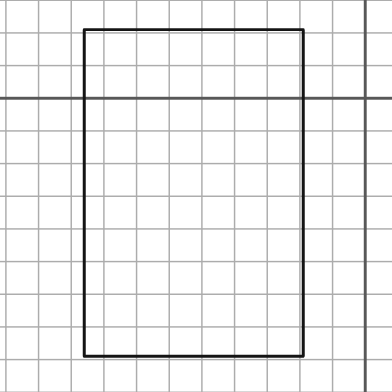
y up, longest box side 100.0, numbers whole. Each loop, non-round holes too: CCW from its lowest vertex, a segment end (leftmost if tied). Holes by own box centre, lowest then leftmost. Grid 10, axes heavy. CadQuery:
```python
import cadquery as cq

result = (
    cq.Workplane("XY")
    .moveTo(-86.0, -79.0)
    .lineTo(-19.0, -79.0)
    .lineTo(-19.0, 21.0)
    .lineTo(-86.0, 21.0)
    .close()
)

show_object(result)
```